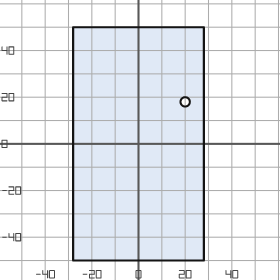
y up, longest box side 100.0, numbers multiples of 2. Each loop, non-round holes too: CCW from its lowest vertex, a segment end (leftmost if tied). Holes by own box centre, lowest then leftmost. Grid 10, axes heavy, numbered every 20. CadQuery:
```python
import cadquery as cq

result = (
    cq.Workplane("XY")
    .moveTo(-28.0, -50.0)
    .lineTo(28.0, -50.0)
    .lineTo(28.0, 50.0)
    .lineTo(-28.0, 50.0)
    .close()
    .moveTo(20.0, 18.0)
    .circle(2.0)
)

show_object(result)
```